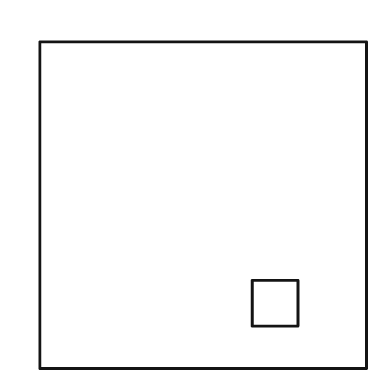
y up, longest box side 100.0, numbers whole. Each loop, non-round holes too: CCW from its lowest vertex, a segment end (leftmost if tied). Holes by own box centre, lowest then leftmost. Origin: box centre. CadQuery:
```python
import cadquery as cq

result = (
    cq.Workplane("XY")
    .moveTo(-50.0, -50.0)
    .lineTo(50.0, -50.0)
    .lineTo(50.0, 50.0)
    .lineTo(-50.0, 50.0)
    .close()
    .moveTo(15.0, -37.0)
    .lineTo(29.0, -37.0)
    .lineTo(29.0, -23.0)
    .lineTo(15.0, -23.0)
    .close()
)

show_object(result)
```